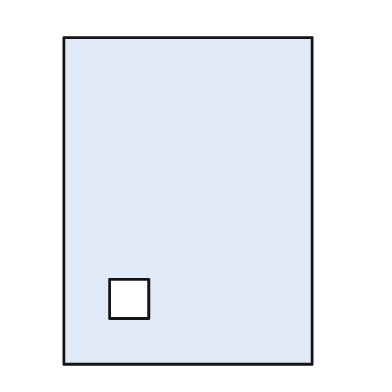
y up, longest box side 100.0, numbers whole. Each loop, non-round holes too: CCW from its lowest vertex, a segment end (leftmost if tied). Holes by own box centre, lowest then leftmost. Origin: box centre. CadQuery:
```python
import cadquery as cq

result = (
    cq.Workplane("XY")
    .moveTo(-38.0, -50.0)
    .lineTo(38.0, -50.0)
    .lineTo(38.0, 50.0)
    .lineTo(-38.0, 50.0)
    .close()
    .moveTo(-24.0, -36.0)
    .lineTo(-12.0, -36.0)
    .lineTo(-12.0, -24.0)
    .lineTo(-24.0, -24.0)
    .close()
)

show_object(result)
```